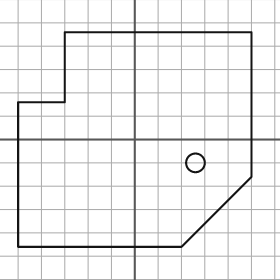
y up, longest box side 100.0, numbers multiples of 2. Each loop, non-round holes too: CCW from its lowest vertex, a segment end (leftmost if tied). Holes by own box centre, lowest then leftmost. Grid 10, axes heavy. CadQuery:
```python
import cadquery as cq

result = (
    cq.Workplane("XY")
    .moveTo(-50.0, -46.0)
    .lineTo(20.0, -46.0)
    .lineTo(50.0, -16.0)
    .lineTo(50.0, 46.0)
    .lineTo(-30.0, 46.0)
    .lineTo(-30.0, 16.0)
    .lineTo(-50.0, 16.0)
    .close()
    .moveTo(26.0, -10.0)
    .circle(4.0)
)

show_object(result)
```